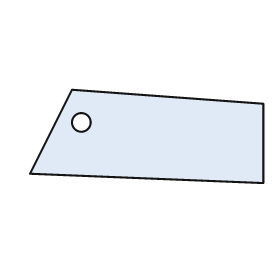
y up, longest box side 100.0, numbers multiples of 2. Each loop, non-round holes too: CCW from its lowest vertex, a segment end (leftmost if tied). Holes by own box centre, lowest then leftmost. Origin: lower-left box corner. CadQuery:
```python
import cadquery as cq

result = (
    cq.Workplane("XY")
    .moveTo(100.0, 0.0)
    .lineTo(100.0, 34.0)
    .lineTo(18.0, 40.0)
    .lineTo(0.0, 4.0)
    .close()
    .moveTo(22.0, 26.0)
    .circle(4.0)
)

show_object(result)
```